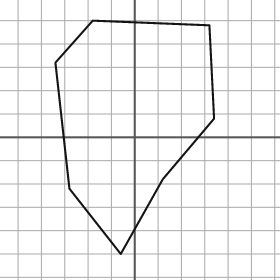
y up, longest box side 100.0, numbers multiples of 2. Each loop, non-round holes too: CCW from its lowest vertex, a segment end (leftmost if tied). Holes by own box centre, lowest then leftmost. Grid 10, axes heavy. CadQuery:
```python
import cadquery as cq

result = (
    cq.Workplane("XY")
    .moveTo(-6.0, -50.0)
    .lineTo(12.0, -18.0)
    .lineTo(34.0, 8.0)
    .lineTo(32.0, 48.0)
    .lineTo(-18.0, 50.0)
    .lineTo(-34.0, 32.0)
    .lineTo(-28.0, -22.0)
    .close()
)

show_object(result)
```